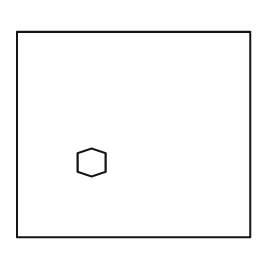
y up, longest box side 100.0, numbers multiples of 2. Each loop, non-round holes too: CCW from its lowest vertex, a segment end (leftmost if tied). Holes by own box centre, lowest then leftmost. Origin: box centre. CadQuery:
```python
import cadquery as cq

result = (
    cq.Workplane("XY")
    .moveTo(-50.0, -44.0)
    .lineTo(50.0, -44.0)
    .lineTo(50.0, 44.0)
    .lineTo(-50.0, 44.0)
    .close()
    .moveTo(-18.0, -18.0)
    .lineTo(-12.0, -16.0)
    .lineTo(-12.0, -8.0)
    .lineTo(-18.0, -6.0)
    .lineTo(-24.0, -8.0)
    .lineTo(-24.0, -16.0)
    .close()
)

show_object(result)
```